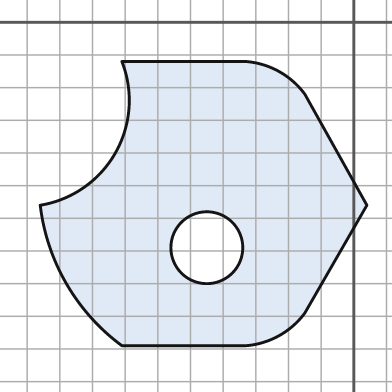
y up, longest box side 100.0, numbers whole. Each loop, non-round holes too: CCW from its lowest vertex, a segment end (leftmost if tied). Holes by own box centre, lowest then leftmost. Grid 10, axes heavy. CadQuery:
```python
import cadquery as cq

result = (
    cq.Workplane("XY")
    .moveTo(-71.0, -99.0)
    .lineTo(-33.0, -99.0)
    .threePointArc((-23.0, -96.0), (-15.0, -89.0))
    .lineTo(4.0, -56.0)
    .lineTo(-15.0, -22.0)
    .threePointArc((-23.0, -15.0), (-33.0, -12.0))
    .lineTo(-71.0, -12.0)
    .threePointArc((-73.0, -40.0), (-96.0, -56.0))
    .threePointArc((-88.0, -80.0), (-71.0, -99.0))
    .close()
    .moveTo(-45.0, -69.0)
    .circle(11.0)
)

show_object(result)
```